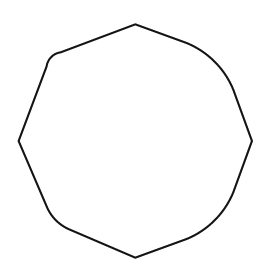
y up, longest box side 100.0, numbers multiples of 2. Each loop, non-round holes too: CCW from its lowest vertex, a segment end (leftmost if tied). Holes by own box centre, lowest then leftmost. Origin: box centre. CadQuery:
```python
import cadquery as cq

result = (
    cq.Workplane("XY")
    .moveTo(0.0, -50.0)
    .lineTo(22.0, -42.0)
    .threePointArc((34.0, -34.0), (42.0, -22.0))
    .lineTo(50.0, 0.0)
    .lineTo(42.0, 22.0)
    .threePointArc((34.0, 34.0), (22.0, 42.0))
    .lineTo(0.0, 50.0)
    .lineTo(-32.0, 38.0)
    .threePointArc((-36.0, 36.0), (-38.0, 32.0))
    .lineTo(-50.0, 0.0)
    .lineTo(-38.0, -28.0)
    .threePointArc((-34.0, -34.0), (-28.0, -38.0))
    .close()
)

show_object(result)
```